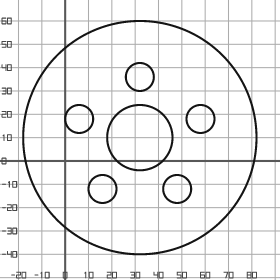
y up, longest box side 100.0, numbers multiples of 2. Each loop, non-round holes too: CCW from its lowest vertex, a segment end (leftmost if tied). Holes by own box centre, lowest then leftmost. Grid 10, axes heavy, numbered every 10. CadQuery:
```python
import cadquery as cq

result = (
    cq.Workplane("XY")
    .moveTo(32.0, 10.0)
    .circle(50.0)
    .moveTo(16.0, -12.0)
    .circle(6.0)
    .moveTo(48.0, -12.0)
    .circle(6.0)
    .moveTo(32.0, 10.0)
    .circle(14.0)
    .moveTo(6.0, 18.0)
    .circle(6.0)
    .moveTo(58.0, 18.0)
    .circle(6.0)
    .moveTo(32.0, 36.0)
    .circle(6.0)
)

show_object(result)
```